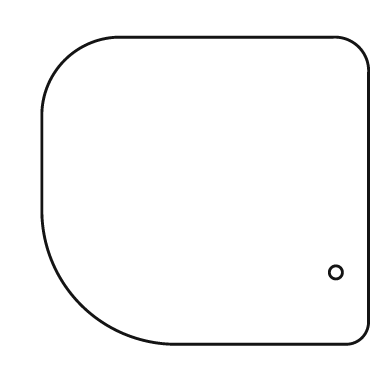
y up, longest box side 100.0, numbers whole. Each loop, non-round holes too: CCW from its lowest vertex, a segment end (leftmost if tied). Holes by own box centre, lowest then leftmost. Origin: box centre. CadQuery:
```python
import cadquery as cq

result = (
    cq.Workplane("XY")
    .moveTo(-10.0, -47.0)
    .lineTo(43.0, -47.0)
    .threePointArc((48.0, -45.0), (50.0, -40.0))
    .lineTo(50.0, 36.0)
    .threePointArc((47.0, 44.0), (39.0, 47.0))
    .lineTo(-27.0, 47.0)
    .threePointArc((-43.0, 40.0), (-50.0, 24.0))
    .lineTo(-50.0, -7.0)
    .threePointArc((-38.0, -35.0), (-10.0, -47.0))
    .close()
    .moveTo(40.0, -25.0)
    .circle(2.0)
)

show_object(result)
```